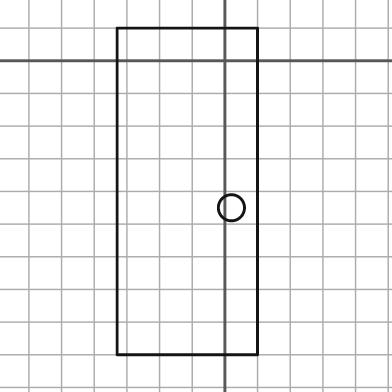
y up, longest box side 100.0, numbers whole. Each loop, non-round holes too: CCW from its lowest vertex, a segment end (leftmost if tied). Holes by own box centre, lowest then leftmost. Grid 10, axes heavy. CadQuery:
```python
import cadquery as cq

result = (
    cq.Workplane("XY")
    .moveTo(-33.0, -90.0)
    .lineTo(10.0, -90.0)
    .lineTo(10.0, 10.0)
    .lineTo(-33.0, 10.0)
    .close()
    .moveTo(2.0, -45.0)
    .circle(4.0)
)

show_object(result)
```